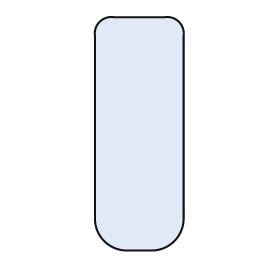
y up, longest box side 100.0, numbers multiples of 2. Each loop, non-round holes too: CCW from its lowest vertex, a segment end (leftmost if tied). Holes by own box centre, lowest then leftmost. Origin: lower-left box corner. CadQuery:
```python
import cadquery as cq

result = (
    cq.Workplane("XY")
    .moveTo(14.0, 0.0)
    .lineTo(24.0, 0.0)
    .threePointArc((34.0, 4.0), (38.0, 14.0))
    .lineTo(38.0, 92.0)
    .threePointArc((36.0, 98.0), (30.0, 100.0))
    .lineTo(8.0, 100.0)
    .threePointArc((2.0, 98.0), (0.0, 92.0))
    .lineTo(0.0, 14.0)
    .threePointArc((4.0, 4.0), (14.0, 0.0))
    .close()
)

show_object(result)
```